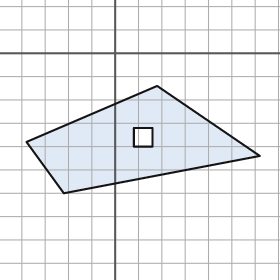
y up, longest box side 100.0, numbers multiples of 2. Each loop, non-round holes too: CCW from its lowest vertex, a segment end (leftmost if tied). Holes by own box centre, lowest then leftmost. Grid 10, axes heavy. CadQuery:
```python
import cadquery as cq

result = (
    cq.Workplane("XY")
    .moveTo(-22.0, -60.0)
    .lineTo(62.0, -44.0)
    .lineTo(18.0, -14.0)
    .lineTo(-38.0, -38.0)
    .close()
    .moveTo(8.0, -40.0)
    .lineTo(16.0, -40.0)
    .lineTo(16.0, -32.0)
    .lineTo(8.0, -32.0)
    .close()
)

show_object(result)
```